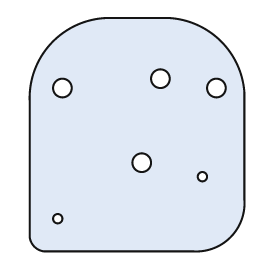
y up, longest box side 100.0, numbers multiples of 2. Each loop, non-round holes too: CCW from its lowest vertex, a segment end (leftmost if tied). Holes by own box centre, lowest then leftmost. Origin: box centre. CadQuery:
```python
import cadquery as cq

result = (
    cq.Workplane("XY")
    .moveTo(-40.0, -50.0)
    .lineTo(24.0, -50.0)
    .threePointArc((40.0, -44.0), (46.0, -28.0))
    .lineTo(46.0, 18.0)
    .threePointArc((36.0, 40.0), (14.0, 50.0))
    .lineTo(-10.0, 50.0)
    .threePointArc((-36.0, 40.0), (-46.0, 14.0))
    .lineTo(-46.0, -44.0)
    .threePointArc((-44.0, -48.0), (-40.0, -50.0))
    .close()
    .moveTo(-34.0, -36.0)
    .circle(2.0)
    .moveTo(28.0, -18.0)
    .circle(2.0)
    .moveTo(2.0, -12.0)
    .circle(4.0)
    .moveTo(-32.0, 20.0)
    .circle(4.0)
    .moveTo(34.0, 20.0)
    .circle(4.0)
    .moveTo(10.0, 24.0)
    .circle(4.0)
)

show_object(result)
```